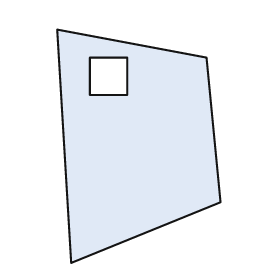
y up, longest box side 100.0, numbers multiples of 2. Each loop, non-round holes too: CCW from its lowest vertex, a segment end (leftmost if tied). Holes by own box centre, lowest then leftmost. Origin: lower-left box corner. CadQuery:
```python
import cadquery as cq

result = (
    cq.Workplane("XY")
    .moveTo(6.0, 0.0)
    .lineTo(70.0, 26.0)
    .lineTo(64.0, 88.0)
    .lineTo(0.0, 100.0)
    .close()
    .moveTo(14.0, 72.0)
    .lineTo(30.0, 72.0)
    .lineTo(30.0, 88.0)
    .lineTo(14.0, 88.0)
    .close()
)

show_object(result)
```